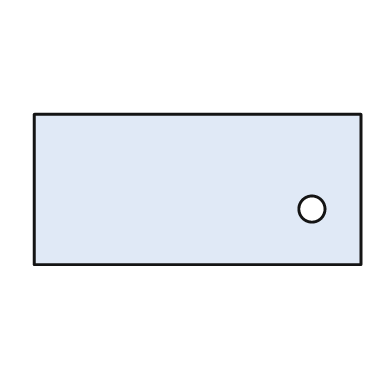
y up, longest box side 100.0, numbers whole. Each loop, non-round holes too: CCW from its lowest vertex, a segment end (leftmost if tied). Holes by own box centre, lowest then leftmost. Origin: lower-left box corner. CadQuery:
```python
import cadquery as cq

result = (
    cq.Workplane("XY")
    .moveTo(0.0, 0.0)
    .lineTo(100.0, 0.0)
    .lineTo(100.0, 46.0)
    .lineTo(0.0, 46.0)
    .close()
    .moveTo(85.0, 17.0)
    .circle(4.0)
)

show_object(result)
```